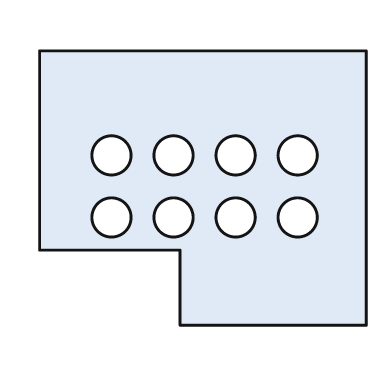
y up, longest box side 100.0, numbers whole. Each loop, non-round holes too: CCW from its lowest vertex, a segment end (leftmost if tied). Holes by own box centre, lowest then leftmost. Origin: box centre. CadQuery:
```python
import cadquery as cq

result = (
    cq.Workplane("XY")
    .moveTo(-7.0, -42.0)
    .lineTo(50.0, -42.0)
    .lineTo(50.0, 42.0)
    .lineTo(-50.0, 42.0)
    .lineTo(-50.0, -19.0)
    .lineTo(-7.0, -19.0)
    .close()
    .moveTo(-28.0, -9.0)
    .circle(6.0)
    .moveTo(-9.0, -9.0)
    .circle(6.0)
    .moveTo(10.0, -9.0)
    .circle(6.0)
    .moveTo(29.0, -9.0)
    .circle(6.0)
    .moveTo(-28.0, 10.0)
    .circle(6.0)
    .moveTo(-9.0, 10.0)
    .circle(6.0)
    .moveTo(10.0, 10.0)
    .circle(6.0)
    .moveTo(29.0, 10.0)
    .circle(6.0)
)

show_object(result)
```